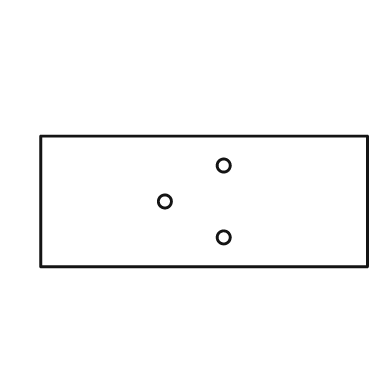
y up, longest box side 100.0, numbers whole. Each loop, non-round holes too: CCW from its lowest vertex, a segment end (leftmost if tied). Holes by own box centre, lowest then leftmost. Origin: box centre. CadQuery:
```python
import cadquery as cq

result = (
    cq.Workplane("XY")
    .moveTo(-50.0, -20.0)
    .lineTo(50.0, -20.0)
    .lineTo(50.0, 20.0)
    .lineTo(-50.0, 20.0)
    .close()
    .moveTo(6.0, -11.0)
    .circle(2.0)
    .moveTo(-12.0, 0.0)
    .circle(2.0)
    .moveTo(6.0, 11.0)
    .circle(2.0)
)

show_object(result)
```